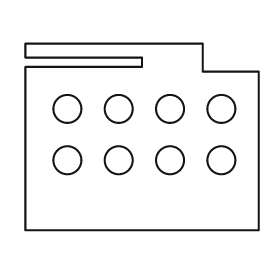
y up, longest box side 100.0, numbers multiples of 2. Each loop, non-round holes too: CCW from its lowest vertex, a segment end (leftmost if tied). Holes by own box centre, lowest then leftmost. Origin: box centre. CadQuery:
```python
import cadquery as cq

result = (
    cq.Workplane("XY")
    .moveTo(-50.0, -40.0)
    .lineTo(50.0, -40.0)
    .lineTo(50.0, 28.0)
    .lineTo(26.0, 28.0)
    .lineTo(26.0, 40.0)
    .lineTo(-50.0, 40.0)
    .lineTo(-50.0, 34.0)
    .lineTo(0.0, 34.0)
    .lineTo(0.0, 30.0)
    .lineTo(-50.0, 30.0)
    .close()
    .moveTo(-32.0, -10.0)
    .circle(6.0)
    .moveTo(-10.0, -10.0)
    .circle(6.0)
    .moveTo(12.0, -10.0)
    .circle(6.0)
    .moveTo(34.0, -10.0)
    .circle(6.0)
    .moveTo(-32.0, 12.0)
    .circle(6.0)
    .moveTo(-10.0, 12.0)
    .circle(6.0)
    .moveTo(12.0, 12.0)
    .circle(6.0)
    .moveTo(34.0, 12.0)
    .circle(6.0)
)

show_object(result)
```